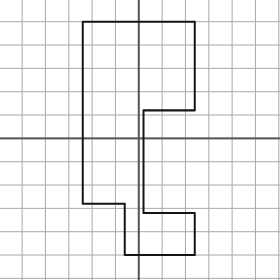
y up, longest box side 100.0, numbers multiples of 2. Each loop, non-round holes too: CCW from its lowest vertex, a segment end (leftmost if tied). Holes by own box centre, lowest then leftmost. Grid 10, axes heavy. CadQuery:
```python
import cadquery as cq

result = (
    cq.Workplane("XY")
    .moveTo(-6.0, -50.0)
    .lineTo(24.0, -50.0)
    .lineTo(24.0, -32.0)
    .lineTo(2.0, -32.0)
    .lineTo(2.0, 12.0)
    .lineTo(24.0, 12.0)
    .lineTo(24.0, 50.0)
    .lineTo(-24.0, 50.0)
    .lineTo(-24.0, -28.0)
    .lineTo(-6.0, -28.0)
    .close()
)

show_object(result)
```